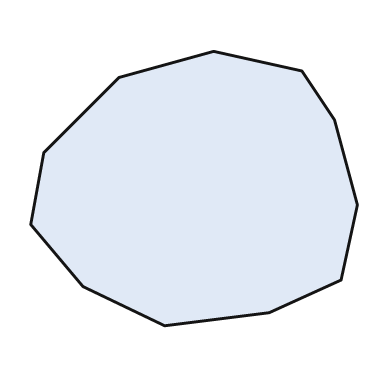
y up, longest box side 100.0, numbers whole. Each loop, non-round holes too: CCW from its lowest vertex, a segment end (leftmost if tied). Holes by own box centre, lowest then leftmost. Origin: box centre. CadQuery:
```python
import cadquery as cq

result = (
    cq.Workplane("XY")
    .moveTo(-9.0, -42.0)
    .lineTo(23.0, -38.0)
    .lineTo(45.0, -28.0)
    .lineTo(50.0, -5.0)
    .lineTo(43.0, 21.0)
    .lineTo(33.0, 36.0)
    .lineTo(6.0, 42.0)
    .lineTo(-23.0, 34.0)
    .lineTo(-46.0, 11.0)
    .lineTo(-50.0, -11.0)
    .lineTo(-34.0, -30.0)
    .close()
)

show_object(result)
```